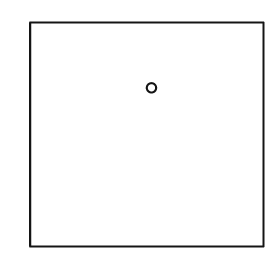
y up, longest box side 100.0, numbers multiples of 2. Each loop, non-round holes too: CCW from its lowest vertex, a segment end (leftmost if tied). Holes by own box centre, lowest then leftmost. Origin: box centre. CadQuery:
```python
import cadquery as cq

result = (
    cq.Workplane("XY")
    .moveTo(-50.0, -48.0)
    .lineTo(50.0, -48.0)
    .lineTo(50.0, 48.0)
    .lineTo(-50.0, 48.0)
    .close()
    .moveTo(2.0, 20.0)
    .circle(2.0)
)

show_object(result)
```